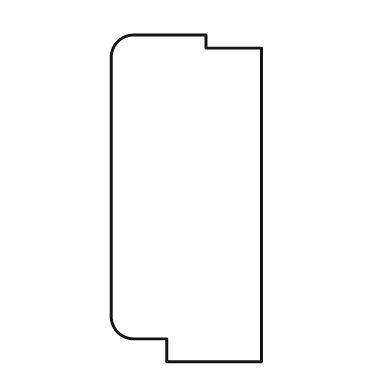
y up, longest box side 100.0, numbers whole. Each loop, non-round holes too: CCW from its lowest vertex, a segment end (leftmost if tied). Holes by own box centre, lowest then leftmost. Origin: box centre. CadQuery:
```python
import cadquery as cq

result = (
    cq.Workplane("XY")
    .moveTo(-6.0, -50.0)
    .lineTo(23.0, -50.0)
    .lineTo(23.0, 46.0)
    .lineTo(6.0, 46.0)
    .lineTo(6.0, 50.0)
    .lineTo(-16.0, 50.0)
    .threePointArc((-21.0, 48.0), (-23.0, 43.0))
    .lineTo(-23.0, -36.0)
    .threePointArc((-21.0, -41.0), (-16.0, -43.0))
    .lineTo(-6.0, -43.0)
    .close()
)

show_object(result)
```